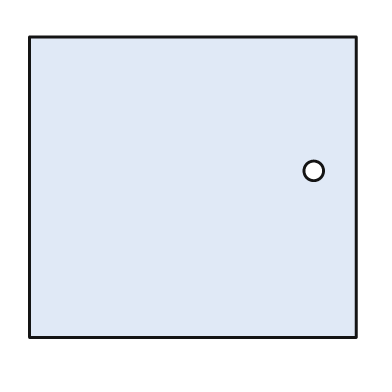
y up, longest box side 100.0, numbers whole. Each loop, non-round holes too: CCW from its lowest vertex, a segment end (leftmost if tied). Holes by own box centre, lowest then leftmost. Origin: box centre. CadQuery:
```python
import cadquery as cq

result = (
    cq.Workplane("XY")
    .moveTo(-50.0, -46.0)
    .lineTo(50.0, -46.0)
    .lineTo(50.0, 46.0)
    .lineTo(-50.0, 46.0)
    .close()
    .moveTo(37.0, 5.0)
    .circle(3.0)
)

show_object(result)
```